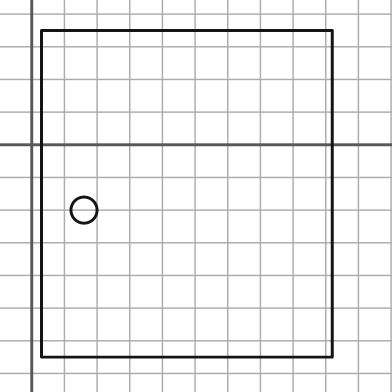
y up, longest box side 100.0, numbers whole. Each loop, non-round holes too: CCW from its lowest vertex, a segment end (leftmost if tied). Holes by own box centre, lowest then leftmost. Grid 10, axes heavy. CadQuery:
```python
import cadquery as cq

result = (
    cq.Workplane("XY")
    .moveTo(3.0, -65.0)
    .lineTo(92.0, -65.0)
    .lineTo(92.0, 35.0)
    .lineTo(3.0, 35.0)
    .close()
    .moveTo(16.0, -20.0)
    .circle(4.0)
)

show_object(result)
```